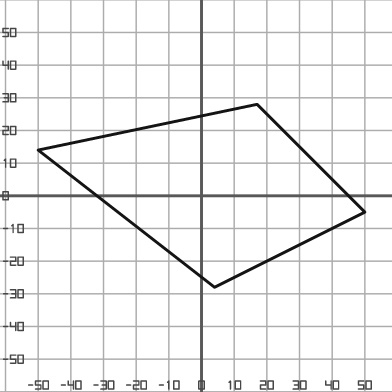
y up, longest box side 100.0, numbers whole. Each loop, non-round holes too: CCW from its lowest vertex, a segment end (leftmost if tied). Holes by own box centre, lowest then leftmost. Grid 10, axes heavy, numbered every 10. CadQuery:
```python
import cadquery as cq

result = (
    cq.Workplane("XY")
    .moveTo(4.0, -28.0)
    .lineTo(50.0, -5.0)
    .lineTo(17.0, 28.0)
    .lineTo(-50.0, 14.0)
    .close()
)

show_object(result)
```